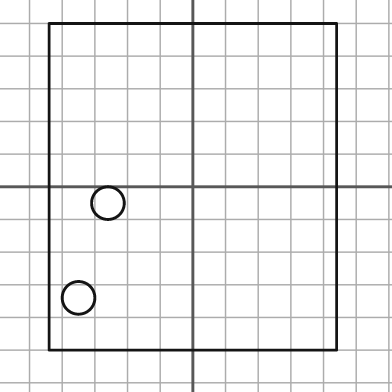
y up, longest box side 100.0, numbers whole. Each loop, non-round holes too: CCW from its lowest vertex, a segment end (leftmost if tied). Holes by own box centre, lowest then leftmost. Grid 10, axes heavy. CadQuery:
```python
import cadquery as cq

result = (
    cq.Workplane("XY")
    .moveTo(-44.0, -50.0)
    .lineTo(44.0, -50.0)
    .lineTo(44.0, 50.0)
    .lineTo(-44.0, 50.0)
    .close()
    .moveTo(-35.0, -34.0)
    .circle(5.0)
    .moveTo(-26.0, -5.0)
    .circle(5.0)
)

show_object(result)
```